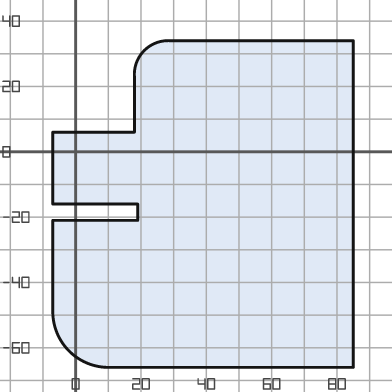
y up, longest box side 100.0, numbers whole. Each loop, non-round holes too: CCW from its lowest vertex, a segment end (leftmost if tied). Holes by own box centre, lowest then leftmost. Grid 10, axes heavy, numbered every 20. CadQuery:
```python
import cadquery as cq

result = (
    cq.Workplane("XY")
    .moveTo(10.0, -66.0)
    .lineTo(85.0, -66.0)
    .lineTo(85.0, 34.0)
    .lineTo(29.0, 34.0)
    .threePointArc((21.0, 31.0), (18.0, 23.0))
    .lineTo(18.0, 6.0)
    .lineTo(-7.0, 6.0)
    .lineTo(-7.0, -16.0)
    .lineTo(19.0, -16.0)
    .lineTo(19.0, -21.0)
    .lineTo(-7.0, -21.0)
    .lineTo(-7.0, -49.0)
    .threePointArc((-2.0, -61.0), (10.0, -66.0))
    .close()
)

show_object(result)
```